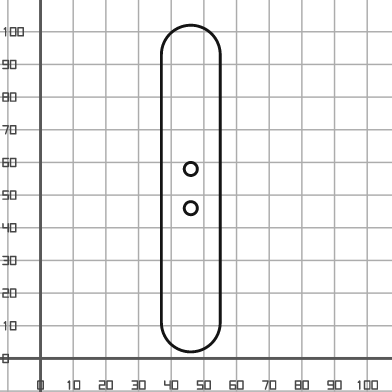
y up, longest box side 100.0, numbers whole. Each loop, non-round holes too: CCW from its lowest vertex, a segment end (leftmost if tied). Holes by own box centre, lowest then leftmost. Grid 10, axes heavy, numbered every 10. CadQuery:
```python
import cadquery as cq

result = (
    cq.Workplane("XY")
    .moveTo(37.0, 11.0)
    .threePointArc((46.0, 2.0), (55.0, 11.0))
    .lineTo(55.0, 93.0)
    .threePointArc((46.0, 102.0), (37.0, 93.0))
    .close()
    .moveTo(46.0, 46.0)
    .circle(2.0)
    .moveTo(46.0, 58.0)
    .circle(2.0)
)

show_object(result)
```